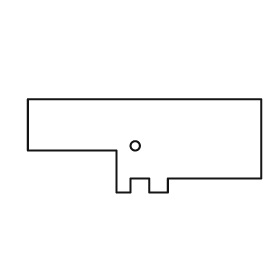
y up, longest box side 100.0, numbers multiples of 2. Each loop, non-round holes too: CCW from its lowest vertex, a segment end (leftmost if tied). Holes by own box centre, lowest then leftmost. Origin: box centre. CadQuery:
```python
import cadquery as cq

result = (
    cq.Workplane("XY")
    .moveTo(-12.0, -20.0)
    .lineTo(-6.0, -20.0)
    .lineTo(-6.0, -14.0)
    .lineTo(2.0, -14.0)
    .lineTo(2.0, -20.0)
    .lineTo(10.0, -20.0)
    .lineTo(10.0, -14.0)
    .lineTo(50.0, -14.0)
    .lineTo(50.0, 20.0)
    .lineTo(-50.0, 20.0)
    .lineTo(-50.0, -2.0)
    .lineTo(-12.0, -2.0)
    .close()
    .moveTo(-4.0, 0.0)
    .circle(2.0)
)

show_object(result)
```